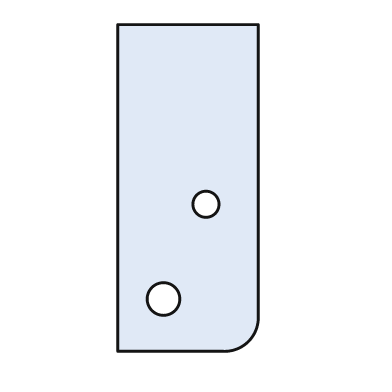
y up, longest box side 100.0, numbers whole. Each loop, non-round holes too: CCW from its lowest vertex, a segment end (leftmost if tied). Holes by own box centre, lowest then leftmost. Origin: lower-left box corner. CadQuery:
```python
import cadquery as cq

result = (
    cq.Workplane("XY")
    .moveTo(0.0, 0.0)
    .lineTo(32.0, 0.0)
    .threePointArc((40.0, 3.0), (43.0, 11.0))
    .lineTo(43.0, 100.0)
    .lineTo(0.0, 100.0)
    .close()
    .moveTo(14.0, 16.0)
    .circle(5.0)
    .moveTo(27.0, 45.0)
    .circle(4.0)
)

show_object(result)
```